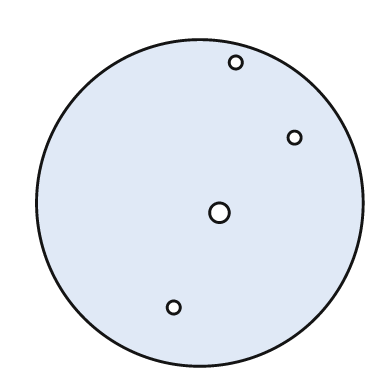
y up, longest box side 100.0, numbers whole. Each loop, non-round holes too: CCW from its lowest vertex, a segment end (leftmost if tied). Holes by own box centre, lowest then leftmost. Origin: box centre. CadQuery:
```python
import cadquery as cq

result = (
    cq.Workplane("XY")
    .moveTo(0.0, 0.0)
    .circle(50.0)
    .moveTo(-8.0, -32.0)
    .circle(2.0)
    .moveTo(6.0, -3.0)
    .circle(3.0)
    .moveTo(29.0, 20.0)
    .circle(2.0)
    .moveTo(11.0, 43.0)
    .circle(2.0)
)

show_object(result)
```